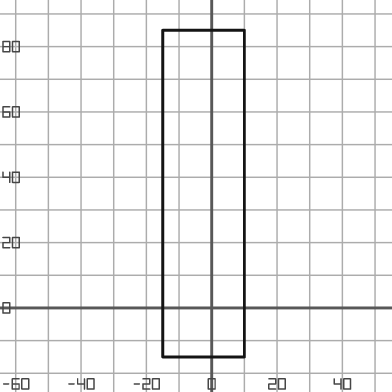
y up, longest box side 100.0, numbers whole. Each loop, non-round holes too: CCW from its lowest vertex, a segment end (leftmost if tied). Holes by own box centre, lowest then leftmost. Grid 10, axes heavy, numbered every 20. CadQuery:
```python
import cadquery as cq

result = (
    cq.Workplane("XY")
    .moveTo(-15.0, -15.0)
    .lineTo(10.0, -15.0)
    .lineTo(10.0, 85.0)
    .lineTo(-15.0, 85.0)
    .close()
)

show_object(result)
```